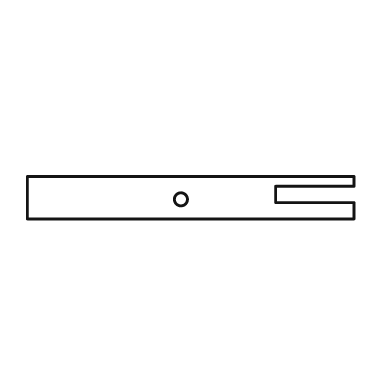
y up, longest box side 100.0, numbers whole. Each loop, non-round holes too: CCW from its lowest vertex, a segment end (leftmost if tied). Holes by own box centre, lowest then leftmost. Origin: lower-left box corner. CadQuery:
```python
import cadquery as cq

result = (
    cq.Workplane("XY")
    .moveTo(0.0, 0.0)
    .lineTo(100.0, 0.0)
    .lineTo(100.0, 5.0)
    .lineTo(76.0, 5.0)
    .lineTo(76.0, 10.0)
    .lineTo(100.0, 10.0)
    .lineTo(100.0, 13.0)
    .lineTo(0.0, 13.0)
    .close()
    .moveTo(47.0, 6.0)
    .circle(2.0)
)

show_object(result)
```